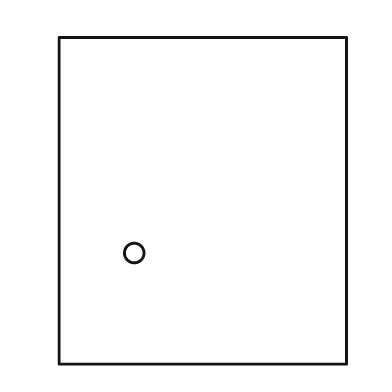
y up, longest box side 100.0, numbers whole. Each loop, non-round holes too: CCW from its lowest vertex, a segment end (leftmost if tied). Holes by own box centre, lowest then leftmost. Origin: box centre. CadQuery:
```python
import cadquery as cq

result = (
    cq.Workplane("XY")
    .moveTo(-44.0, -50.0)
    .lineTo(44.0, -50.0)
    .lineTo(44.0, 50.0)
    .lineTo(-44.0, 50.0)
    .close()
    .moveTo(-21.0, -16.0)
    .circle(3.0)
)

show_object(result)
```